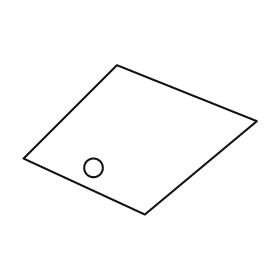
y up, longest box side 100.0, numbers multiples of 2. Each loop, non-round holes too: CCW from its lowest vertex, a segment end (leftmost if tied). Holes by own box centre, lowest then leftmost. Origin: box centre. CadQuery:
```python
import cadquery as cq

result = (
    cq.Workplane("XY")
    .moveTo(2.0, -32.0)
    .lineTo(50.0, 8.0)
    .lineTo(-10.0, 32.0)
    .lineTo(-50.0, -8.0)
    .close()
    .moveTo(-20.0, -12.0)
    .circle(4.0)
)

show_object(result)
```